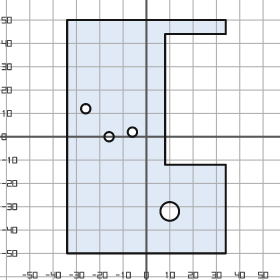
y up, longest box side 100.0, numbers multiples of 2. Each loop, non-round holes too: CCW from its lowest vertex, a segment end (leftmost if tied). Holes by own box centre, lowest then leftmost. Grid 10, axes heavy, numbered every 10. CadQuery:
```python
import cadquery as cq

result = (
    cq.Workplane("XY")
    .moveTo(-34.0, -50.0)
    .lineTo(34.0, -50.0)
    .lineTo(34.0, -12.0)
    .lineTo(8.0, -12.0)
    .lineTo(8.0, 44.0)
    .lineTo(34.0, 44.0)
    .lineTo(34.0, 50.0)
    .lineTo(-34.0, 50.0)
    .close()
    .moveTo(10.0, -32.0)
    .circle(4.0)
    .moveTo(-16.0, 0.0)
    .circle(2.0)
    .moveTo(-6.0, 2.0)
    .circle(2.0)
    .moveTo(-26.0, 12.0)
    .circle(2.0)
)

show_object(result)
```